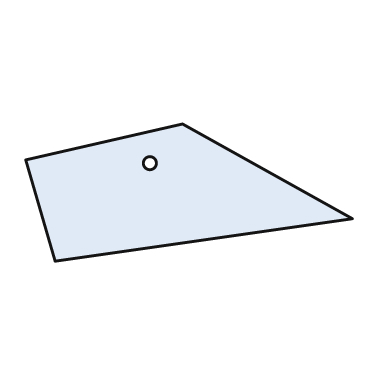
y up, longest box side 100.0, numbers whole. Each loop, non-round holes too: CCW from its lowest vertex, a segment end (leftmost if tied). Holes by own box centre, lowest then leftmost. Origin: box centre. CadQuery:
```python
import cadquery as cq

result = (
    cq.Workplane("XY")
    .moveTo(-41.0, -21.0)
    .lineTo(50.0, -8.0)
    .lineTo(-2.0, 21.0)
    .lineTo(-50.0, 10.0)
    .close()
    .moveTo(-12.0, 9.0)
    .circle(2.0)
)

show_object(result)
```